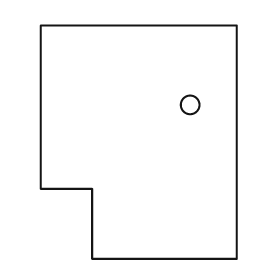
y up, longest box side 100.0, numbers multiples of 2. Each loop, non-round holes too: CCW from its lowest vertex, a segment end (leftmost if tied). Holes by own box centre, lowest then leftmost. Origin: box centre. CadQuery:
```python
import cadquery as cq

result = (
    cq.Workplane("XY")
    .moveTo(-20.0, -50.0)
    .lineTo(42.0, -50.0)
    .lineTo(42.0, 50.0)
    .lineTo(-42.0, 50.0)
    .lineTo(-42.0, -20.0)
    .lineTo(-20.0, -20.0)
    .close()
    .moveTo(22.0, 16.0)
    .circle(4.0)
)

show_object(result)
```